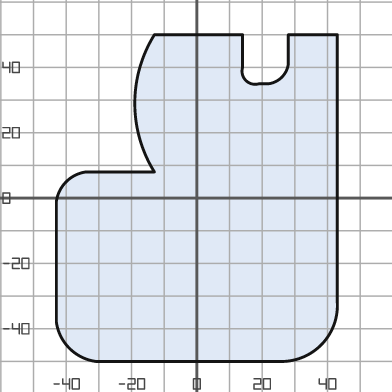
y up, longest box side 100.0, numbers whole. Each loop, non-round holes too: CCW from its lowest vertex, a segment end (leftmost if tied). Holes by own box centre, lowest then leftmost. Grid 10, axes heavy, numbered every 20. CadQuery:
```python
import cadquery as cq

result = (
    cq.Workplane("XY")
    .moveTo(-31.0, -50.0)
    .lineTo(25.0, -50.0)
    .threePointArc((38.0, -45.0), (43.0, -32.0))
    .lineTo(43.0, 50.0)
    .lineTo(28.0, 50.0)
    .lineTo(28.0, 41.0)
    .threePointArc((26.0, 37.0), (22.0, 35.0))
    .lineTo(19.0, 35.0)
    .threePointArc((15.0, 36.0), (14.0, 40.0))
    .lineTo(14.0, 50.0)
    .lineTo(-13.0, 50.0)
    .threePointArc((-19.0, 29.0), (-13.0, 8.0))
    .lineTo(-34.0, 8.0)
    .threePointArc((-40.0, 5.0), (-43.0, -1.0))
    .lineTo(-43.0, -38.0)
    .threePointArc((-39.0, -46.0), (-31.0, -50.0))
    .close()
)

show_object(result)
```